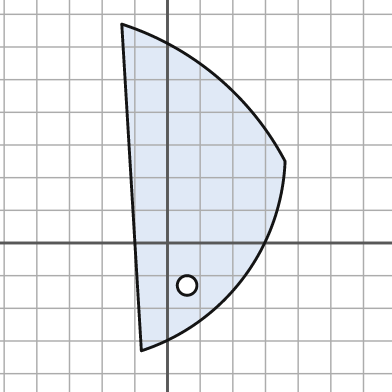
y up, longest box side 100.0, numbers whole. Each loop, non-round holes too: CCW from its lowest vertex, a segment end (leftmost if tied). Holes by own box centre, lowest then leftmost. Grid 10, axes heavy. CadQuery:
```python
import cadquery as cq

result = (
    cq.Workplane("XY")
    .moveTo(-8.0, -33.0)
    .threePointArc((23.0, -11.0), (36.0, 25.0))
    .threePointArc((15.0, 51.0), (-14.0, 67.0))
    .close()
    .moveTo(6.0, -13.0)
    .circle(3.0)
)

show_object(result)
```